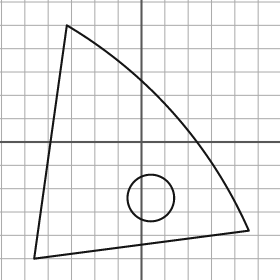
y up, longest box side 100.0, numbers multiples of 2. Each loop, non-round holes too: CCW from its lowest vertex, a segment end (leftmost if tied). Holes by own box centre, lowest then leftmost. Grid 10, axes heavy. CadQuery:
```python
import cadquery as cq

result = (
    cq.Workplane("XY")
    .moveTo(-46.0, -50.0)
    .lineTo(46.0, -38.0)
    .threePointArc((14.0, 12.0), (-32.0, 50.0))
    .close()
    .moveTo(4.0, -24.0)
    .circle(10.0)
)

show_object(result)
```